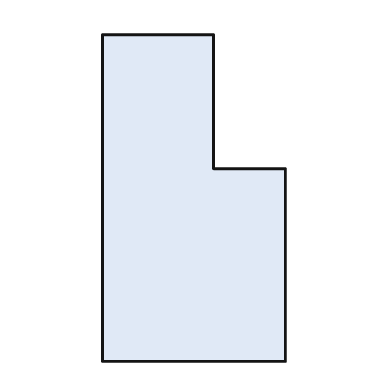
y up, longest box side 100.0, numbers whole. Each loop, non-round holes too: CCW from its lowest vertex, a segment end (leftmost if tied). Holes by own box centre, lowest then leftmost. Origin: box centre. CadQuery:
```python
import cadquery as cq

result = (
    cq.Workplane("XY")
    .moveTo(-28.0, -50.0)
    .lineTo(28.0, -50.0)
    .lineTo(28.0, 9.0)
    .lineTo(6.0, 9.0)
    .lineTo(6.0, 50.0)
    .lineTo(-28.0, 50.0)
    .close()
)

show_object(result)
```